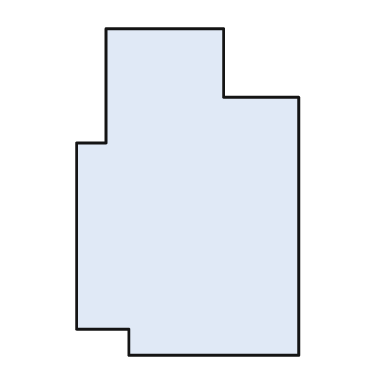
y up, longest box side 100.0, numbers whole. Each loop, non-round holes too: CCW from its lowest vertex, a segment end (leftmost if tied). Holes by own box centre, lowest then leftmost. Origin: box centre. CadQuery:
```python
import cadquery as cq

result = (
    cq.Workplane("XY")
    .moveTo(-18.0, -50.0)
    .lineTo(34.0, -50.0)
    .lineTo(34.0, 29.0)
    .lineTo(11.0, 29.0)
    .lineTo(11.0, 50.0)
    .lineTo(-25.0, 50.0)
    .lineTo(-25.0, 15.0)
    .lineTo(-34.0, 15.0)
    .lineTo(-34.0, -42.0)
    .lineTo(-18.0, -42.0)
    .close()
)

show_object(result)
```